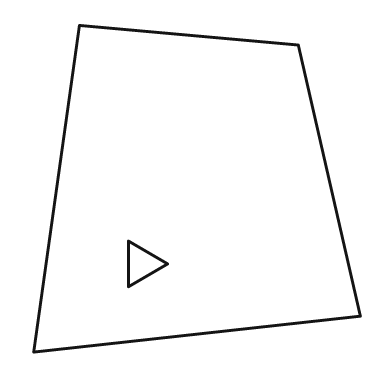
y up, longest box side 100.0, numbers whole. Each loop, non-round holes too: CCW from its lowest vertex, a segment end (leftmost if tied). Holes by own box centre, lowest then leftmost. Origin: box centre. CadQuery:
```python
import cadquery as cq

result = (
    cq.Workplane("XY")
    .moveTo(-50.0, -50.0)
    .lineTo(50.0, -39.0)
    .lineTo(31.0, 44.0)
    .lineTo(-36.0, 50.0)
    .close()
    .moveTo(-21.0, -30.0)
    .lineTo(-9.0, -23.0)
    .lineTo(-21.0, -16.0)
    .close()
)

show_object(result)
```